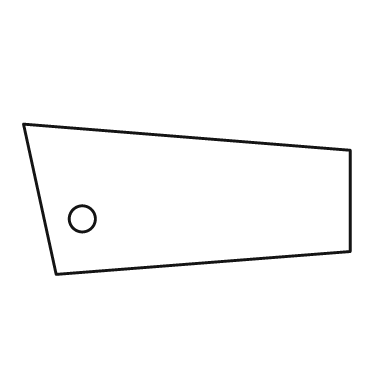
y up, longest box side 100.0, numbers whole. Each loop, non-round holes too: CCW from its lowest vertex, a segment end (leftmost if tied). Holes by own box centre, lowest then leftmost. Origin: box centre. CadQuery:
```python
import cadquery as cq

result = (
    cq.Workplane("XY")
    .moveTo(-40.0, -23.0)
    .lineTo(50.0, -16.0)
    .lineTo(50.0, 15.0)
    .lineTo(-50.0, 23.0)
    .close()
    .moveTo(-32.0, -6.0)
    .circle(4.0)
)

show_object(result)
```